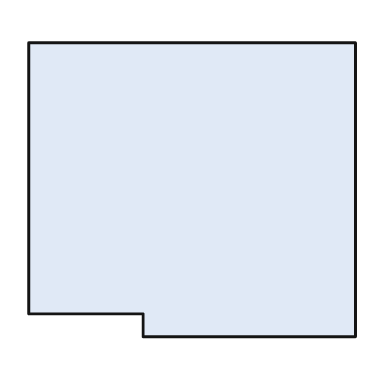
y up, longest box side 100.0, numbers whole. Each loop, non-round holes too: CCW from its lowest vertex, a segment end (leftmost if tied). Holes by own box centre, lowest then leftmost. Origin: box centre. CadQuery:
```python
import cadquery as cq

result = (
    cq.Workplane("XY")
    .moveTo(-15.0, -45.0)
    .lineTo(50.0, -45.0)
    .lineTo(50.0, 45.0)
    .lineTo(-50.0, 45.0)
    .lineTo(-50.0, -38.0)
    .lineTo(-15.0, -38.0)
    .close()
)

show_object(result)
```